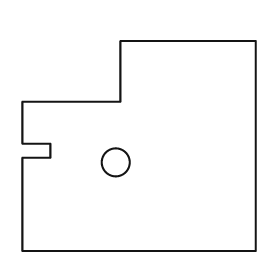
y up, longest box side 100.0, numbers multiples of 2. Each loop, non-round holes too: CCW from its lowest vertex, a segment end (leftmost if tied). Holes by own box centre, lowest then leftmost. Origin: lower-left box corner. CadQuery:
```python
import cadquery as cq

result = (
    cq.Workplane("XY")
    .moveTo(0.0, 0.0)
    .lineTo(100.0, 0.0)
    .lineTo(100.0, 90.0)
    .lineTo(42.0, 90.0)
    .lineTo(42.0, 64.0)
    .lineTo(0.0, 64.0)
    .lineTo(0.0, 46.0)
    .lineTo(12.0, 46.0)
    .lineTo(12.0, 40.0)
    .lineTo(0.0, 40.0)
    .close()
    .moveTo(40.0, 38.0)
    .circle(6.0)
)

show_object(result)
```